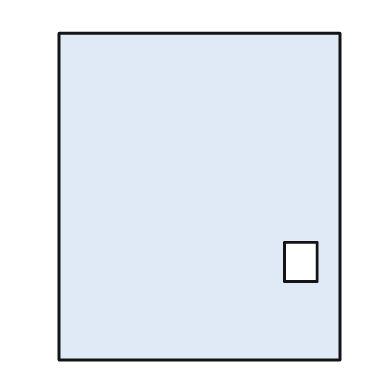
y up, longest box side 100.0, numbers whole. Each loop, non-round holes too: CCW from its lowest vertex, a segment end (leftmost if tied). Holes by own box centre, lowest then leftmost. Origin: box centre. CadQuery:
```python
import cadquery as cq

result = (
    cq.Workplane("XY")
    .moveTo(-43.0, -50.0)
    .lineTo(43.0, -50.0)
    .lineTo(43.0, 50.0)
    .lineTo(-43.0, 50.0)
    .close()
    .moveTo(26.0, -26.0)
    .lineTo(36.0, -26.0)
    .lineTo(36.0, -14.0)
    .lineTo(26.0, -14.0)
    .close()
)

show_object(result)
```